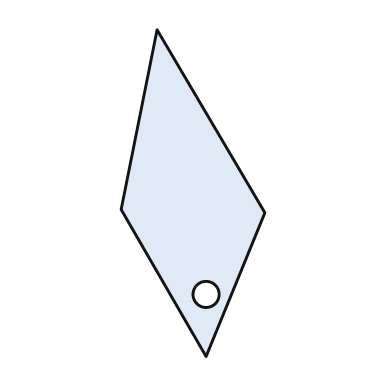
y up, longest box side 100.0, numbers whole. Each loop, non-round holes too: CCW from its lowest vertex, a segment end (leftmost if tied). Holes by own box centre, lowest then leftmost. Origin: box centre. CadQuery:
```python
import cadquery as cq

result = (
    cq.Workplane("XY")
    .moveTo(4.0, -50.0)
    .lineTo(22.0, -6.0)
    .lineTo(-11.0, 50.0)
    .lineTo(-22.0, -5.0)
    .close()
    .moveTo(4.0, -31.0)
    .circle(4.0)
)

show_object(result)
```